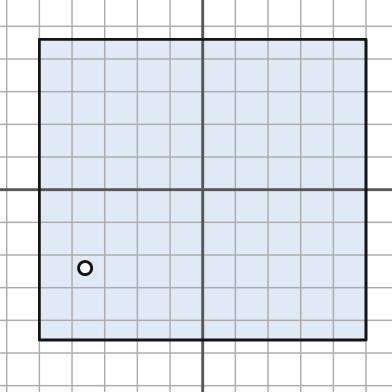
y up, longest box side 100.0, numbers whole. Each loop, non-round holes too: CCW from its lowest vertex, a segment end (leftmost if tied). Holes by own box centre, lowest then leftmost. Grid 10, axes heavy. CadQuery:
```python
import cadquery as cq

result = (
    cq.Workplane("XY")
    .moveTo(-50.0, -46.0)
    .lineTo(50.0, -46.0)
    .lineTo(50.0, 46.0)
    .lineTo(-50.0, 46.0)
    .close()
    .moveTo(-36.0, -24.0)
    .circle(2.0)
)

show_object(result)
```